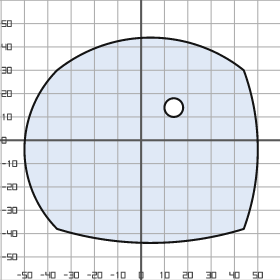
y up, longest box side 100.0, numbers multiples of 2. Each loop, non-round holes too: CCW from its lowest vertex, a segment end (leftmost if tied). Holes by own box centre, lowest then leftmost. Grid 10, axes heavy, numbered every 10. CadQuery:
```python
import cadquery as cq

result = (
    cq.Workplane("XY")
    .moveTo(-36.0, -38.0)
    .threePointArc((4.0, -44.0), (44.0, -38.0))
    .threePointArc((50.0, -4.0), (44.0, 30.0))
    .threePointArc((4.0, 44.0), (-36.0, 30.0))
    .threePointArc((-50.0, -4.0), (-36.0, -38.0))
    .close()
    .moveTo(14.0, 14.0)
    .circle(4.0)
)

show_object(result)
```